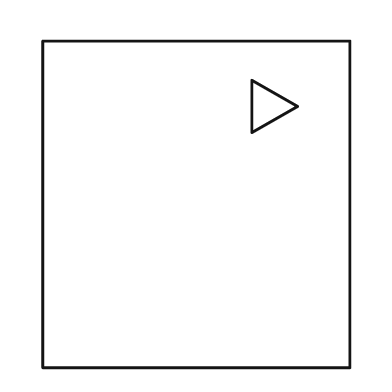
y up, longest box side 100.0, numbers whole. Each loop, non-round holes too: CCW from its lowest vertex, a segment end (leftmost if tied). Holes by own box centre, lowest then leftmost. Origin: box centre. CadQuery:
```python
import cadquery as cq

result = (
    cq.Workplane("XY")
    .moveTo(-47.0, -50.0)
    .lineTo(47.0, -50.0)
    .lineTo(47.0, 50.0)
    .lineTo(-47.0, 50.0)
    .close()
    .moveTo(17.0, 22.0)
    .lineTo(31.0, 30.0)
    .lineTo(17.0, 38.0)
    .close()
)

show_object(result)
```